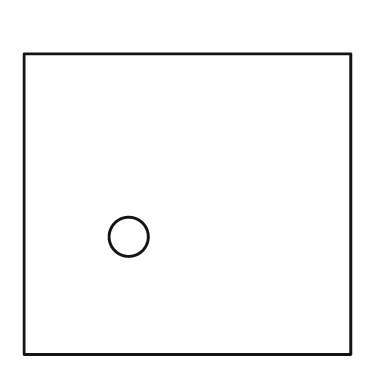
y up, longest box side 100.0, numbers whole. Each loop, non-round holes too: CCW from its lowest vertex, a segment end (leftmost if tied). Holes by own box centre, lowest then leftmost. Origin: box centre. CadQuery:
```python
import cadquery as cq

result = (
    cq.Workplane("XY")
    .moveTo(-50.0, -46.0)
    .lineTo(50.0, -46.0)
    .lineTo(50.0, 46.0)
    .lineTo(-50.0, 46.0)
    .close()
    .moveTo(-18.0, -10.0)
    .circle(6.0)
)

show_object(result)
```